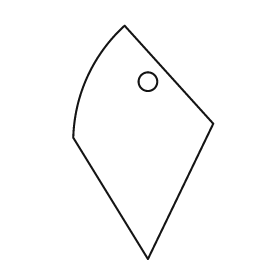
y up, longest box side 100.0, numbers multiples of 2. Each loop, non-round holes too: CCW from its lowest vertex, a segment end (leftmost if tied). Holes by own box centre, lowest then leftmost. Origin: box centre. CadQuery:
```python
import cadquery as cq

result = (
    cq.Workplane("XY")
    .moveTo(2.0, -50.0)
    .lineTo(30.0, 8.0)
    .lineTo(-8.0, 50.0)
    .threePointArc((-24.0, 28.0), (-30.0, 2.0))
    .close()
    .moveTo(2.0, 26.0)
    .circle(4.0)
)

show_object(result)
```